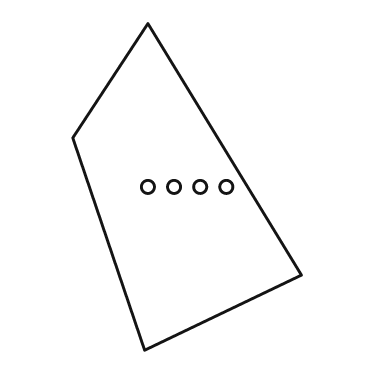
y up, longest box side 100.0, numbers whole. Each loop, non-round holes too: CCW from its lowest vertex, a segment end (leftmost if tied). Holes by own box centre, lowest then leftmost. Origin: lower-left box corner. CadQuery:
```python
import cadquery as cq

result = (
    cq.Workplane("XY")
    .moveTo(22.0, 0.0)
    .lineTo(70.0, 23.0)
    .lineTo(23.0, 100.0)
    .lineTo(0.0, 65.0)
    .close()
    .moveTo(23.0, 50.0)
    .circle(2.0)
    .moveTo(31.0, 50.0)
    .circle(2.0)
    .moveTo(39.0, 50.0)
    .circle(2.0)
    .moveTo(47.0, 50.0)
    .circle(2.0)
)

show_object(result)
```